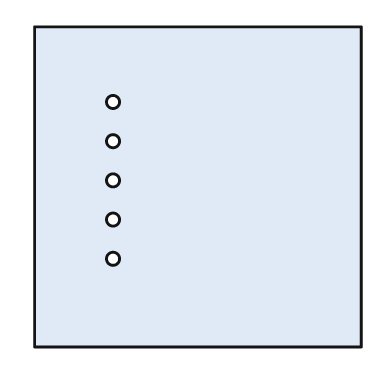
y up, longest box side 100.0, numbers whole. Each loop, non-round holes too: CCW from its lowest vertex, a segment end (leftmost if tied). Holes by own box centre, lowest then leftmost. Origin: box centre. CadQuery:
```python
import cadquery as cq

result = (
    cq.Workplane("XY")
    .moveTo(-50.0, -49.0)
    .lineTo(50.0, -49.0)
    .lineTo(50.0, 49.0)
    .lineTo(-50.0, 49.0)
    .close()
    .moveTo(-26.0, -22.0)
    .circle(2.0)
    .moveTo(-26.0, -10.0)
    .circle(2.0)
    .moveTo(-26.0, 2.0)
    .circle(2.0)
    .moveTo(-26.0, 14.0)
    .circle(2.0)
    .moveTo(-26.0, 26.0)
    .circle(2.0)
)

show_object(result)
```